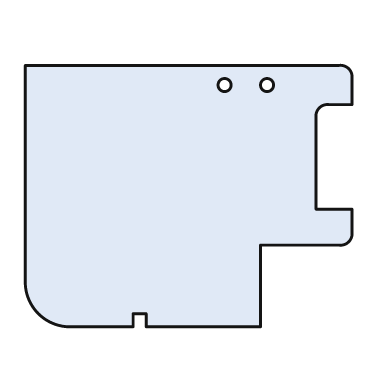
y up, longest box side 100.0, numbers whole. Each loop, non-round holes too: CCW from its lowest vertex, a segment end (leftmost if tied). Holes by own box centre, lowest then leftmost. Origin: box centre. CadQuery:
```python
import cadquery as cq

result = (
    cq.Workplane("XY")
    .moveTo(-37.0, -40.0)
    .lineTo(-17.0, -40.0)
    .lineTo(-17.0, -36.0)
    .lineTo(-13.0, -36.0)
    .lineTo(-13.0, -40.0)
    .lineTo(22.0, -40.0)
    .lineTo(22.0, -15.0)
    .lineTo(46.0, -15.0)
    .threePointArc((49.0, -14.0), (50.0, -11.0))
    .lineTo(50.0, -4.0)
    .lineTo(39.0, -4.0)
    .lineTo(39.0, 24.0)
    .threePointArc((40.0, 27.0), (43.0, 28.0))
    .lineTo(50.0, 28.0)
    .lineTo(50.0, 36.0)
    .threePointArc((49.0, 39.0), (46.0, 40.0))
    .lineTo(-50.0, 40.0)
    .lineTo(-50.0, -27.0)
    .threePointArc((-46.0, -36.0), (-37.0, -40.0))
    .close()
    .moveTo(11.0, 34.0)
    .circle(2.0)
    .moveTo(24.0, 34.0)
    .circle(2.0)
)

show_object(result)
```